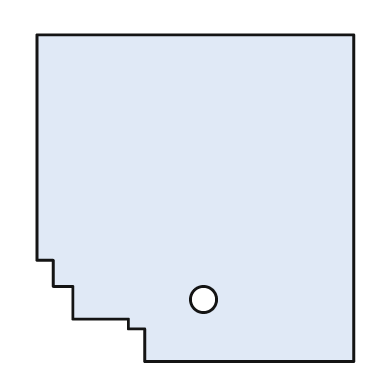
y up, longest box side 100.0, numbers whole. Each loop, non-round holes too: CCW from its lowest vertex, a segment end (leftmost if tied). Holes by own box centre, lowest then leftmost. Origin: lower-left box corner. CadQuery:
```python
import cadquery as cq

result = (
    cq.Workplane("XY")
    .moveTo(33.0, 0.0)
    .lineTo(97.0, 0.0)
    .lineTo(97.0, 100.0)
    .lineTo(0.0, 100.0)
    .lineTo(0.0, 31.0)
    .lineTo(5.0, 31.0)
    .lineTo(5.0, 23.0)
    .lineTo(11.0, 23.0)
    .lineTo(11.0, 13.0)
    .lineTo(28.0, 13.0)
    .lineTo(28.0, 10.0)
    .lineTo(33.0, 10.0)
    .close()
    .moveTo(51.0, 19.0)
    .circle(4.0)
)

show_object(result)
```